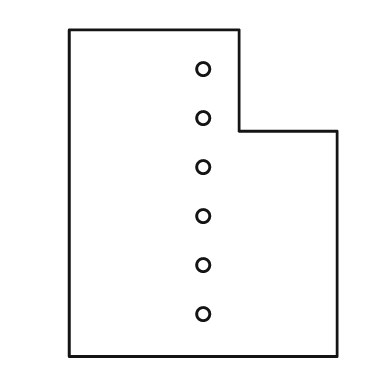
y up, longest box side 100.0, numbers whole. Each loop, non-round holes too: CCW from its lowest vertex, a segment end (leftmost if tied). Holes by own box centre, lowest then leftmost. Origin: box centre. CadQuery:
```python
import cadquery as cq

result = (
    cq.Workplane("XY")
    .moveTo(-41.0, -50.0)
    .lineTo(41.0, -50.0)
    .lineTo(41.0, 19.0)
    .lineTo(11.0, 19.0)
    .lineTo(11.0, 50.0)
    .lineTo(-41.0, 50.0)
    .close()
    .moveTo(0.0, -37.0)
    .circle(2.0)
    .moveTo(0.0, -22.0)
    .circle(2.0)
    .moveTo(0.0, -7.0)
    .circle(2.0)
    .moveTo(0.0, 8.0)
    .circle(2.0)
    .moveTo(0.0, 23.0)
    .circle(2.0)
    .moveTo(0.0, 38.0)
    .circle(2.0)
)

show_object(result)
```